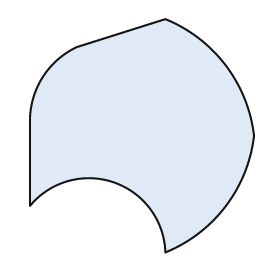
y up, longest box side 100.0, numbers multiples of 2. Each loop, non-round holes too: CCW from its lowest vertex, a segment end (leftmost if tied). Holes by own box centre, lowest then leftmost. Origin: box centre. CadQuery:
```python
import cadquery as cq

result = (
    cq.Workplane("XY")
    .moveTo(10.0, -50.0)
    .threePointArc((36.0, -30.0), (48.0, 0.0))
    .threePointArc((36.0, 30.0), (10.0, 50.0))
    .lineTo(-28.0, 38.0)
    .threePointArc((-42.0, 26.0), (-48.0, 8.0))
    .lineTo(-48.0, -30.0)
    .threePointArc((-12.0, -20.0), (10.0, -50.0))
    .close()
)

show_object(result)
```